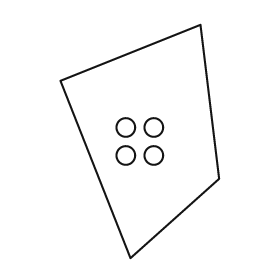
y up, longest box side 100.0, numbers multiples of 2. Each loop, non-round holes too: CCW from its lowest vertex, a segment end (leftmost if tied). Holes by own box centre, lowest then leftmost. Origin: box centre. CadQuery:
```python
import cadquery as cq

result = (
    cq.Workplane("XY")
    .moveTo(-4.0, -50.0)
    .lineTo(34.0, -16.0)
    .lineTo(26.0, 50.0)
    .lineTo(-34.0, 26.0)
    .close()
    .moveTo(-6.0, -6.0)
    .circle(4.0)
    .moveTo(6.0, -6.0)
    .circle(4.0)
    .moveTo(-6.0, 6.0)
    .circle(4.0)
    .moveTo(6.0, 6.0)
    .circle(4.0)
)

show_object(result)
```